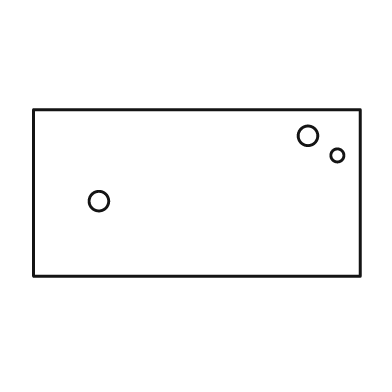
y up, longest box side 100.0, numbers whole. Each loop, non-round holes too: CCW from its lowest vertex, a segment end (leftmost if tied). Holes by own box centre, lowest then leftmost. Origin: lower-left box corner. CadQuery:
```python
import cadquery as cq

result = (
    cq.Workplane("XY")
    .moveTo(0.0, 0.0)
    .lineTo(100.0, 0.0)
    .lineTo(100.0, 51.0)
    .lineTo(0.0, 51.0)
    .close()
    .moveTo(20.0, 23.0)
    .circle(3.0)
    .moveTo(93.0, 37.0)
    .circle(2.0)
    .moveTo(84.0, 43.0)
    .circle(3.0)
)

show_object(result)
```